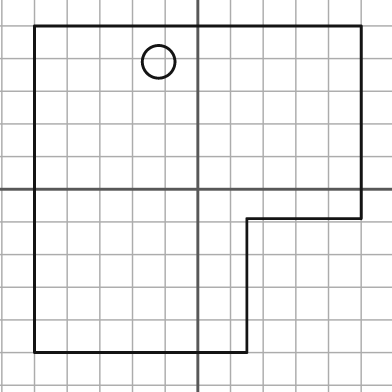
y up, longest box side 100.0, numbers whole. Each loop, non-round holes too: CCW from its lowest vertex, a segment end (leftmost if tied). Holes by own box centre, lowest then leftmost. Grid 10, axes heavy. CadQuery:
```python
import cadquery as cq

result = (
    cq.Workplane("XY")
    .moveTo(-50.0, -50.0)
    .lineTo(15.0, -50.0)
    .lineTo(15.0, -9.0)
    .lineTo(50.0, -9.0)
    .lineTo(50.0, 50.0)
    .lineTo(-50.0, 50.0)
    .close()
    .moveTo(-12.0, 39.0)
    .circle(5.0)
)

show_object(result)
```